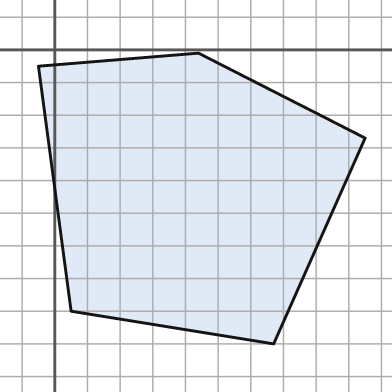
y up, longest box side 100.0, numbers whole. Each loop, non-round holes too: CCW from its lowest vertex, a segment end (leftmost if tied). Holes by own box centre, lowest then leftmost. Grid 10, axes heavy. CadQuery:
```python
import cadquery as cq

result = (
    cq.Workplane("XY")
    .moveTo(67.0, -90.0)
    .lineTo(95.0, -27.0)
    .lineTo(44.0, -1.0)
    .lineTo(-5.0, -5.0)
    .lineTo(5.0, -80.0)
    .close()
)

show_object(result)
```